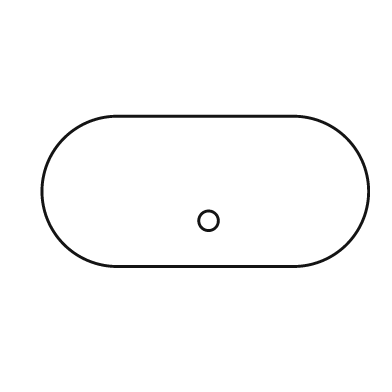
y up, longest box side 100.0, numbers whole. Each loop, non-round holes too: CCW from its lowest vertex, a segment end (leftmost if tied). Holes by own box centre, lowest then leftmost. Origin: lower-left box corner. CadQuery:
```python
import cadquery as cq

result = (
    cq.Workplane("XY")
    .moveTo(23.0, 0.0)
    .lineTo(77.0, 0.0)
    .threePointArc((100.0, 23.0), (77.0, 46.0))
    .lineTo(23.0, 46.0)
    .threePointArc((0.0, 23.0), (23.0, 0.0))
    .close()
    .moveTo(51.0, 14.0)
    .circle(3.0)
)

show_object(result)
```